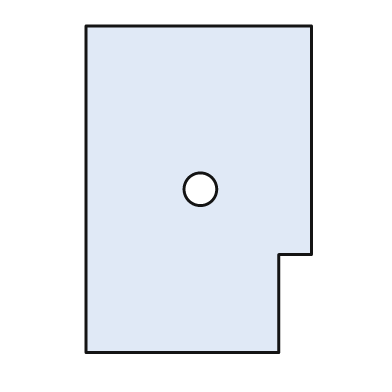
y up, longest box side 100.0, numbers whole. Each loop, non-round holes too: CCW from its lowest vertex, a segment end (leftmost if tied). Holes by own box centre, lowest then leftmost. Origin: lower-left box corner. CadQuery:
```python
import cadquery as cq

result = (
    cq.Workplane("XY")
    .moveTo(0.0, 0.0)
    .lineTo(59.0, 0.0)
    .lineTo(59.0, 30.0)
    .lineTo(69.0, 30.0)
    .lineTo(69.0, 100.0)
    .lineTo(0.0, 100.0)
    .close()
    .moveTo(35.0, 50.0)
    .circle(5.0)
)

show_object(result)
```